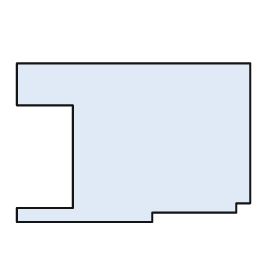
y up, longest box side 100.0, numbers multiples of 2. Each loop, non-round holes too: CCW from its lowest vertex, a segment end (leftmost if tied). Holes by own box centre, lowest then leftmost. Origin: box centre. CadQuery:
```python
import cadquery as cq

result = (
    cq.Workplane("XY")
    .moveTo(-50.0, -34.0)
    .lineTo(8.0, -34.0)
    .lineTo(8.0, -30.0)
    .lineTo(44.0, -30.0)
    .lineTo(44.0, -26.0)
    .lineTo(50.0, -26.0)
    .lineTo(50.0, 34.0)
    .lineTo(-50.0, 34.0)
    .lineTo(-50.0, 16.0)
    .lineTo(-26.0, 16.0)
    .lineTo(-26.0, -28.0)
    .lineTo(-50.0, -28.0)
    .close()
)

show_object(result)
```